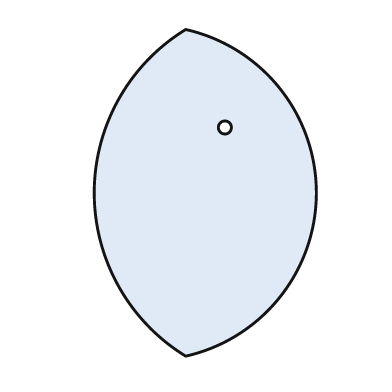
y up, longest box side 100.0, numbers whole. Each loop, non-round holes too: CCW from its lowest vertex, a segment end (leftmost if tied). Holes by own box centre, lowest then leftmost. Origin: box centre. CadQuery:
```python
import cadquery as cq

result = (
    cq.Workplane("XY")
    .moveTo(-6.0, -50.0)
    .threePointArc((34.0, 0.0), (-6.0, 50.0))
    .threePointArc((-34.0, 0.0), (-6.0, -50.0))
    .close()
    .moveTo(6.0, 20.0)
    .circle(2.0)
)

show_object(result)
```